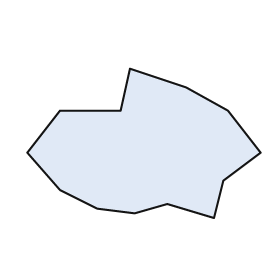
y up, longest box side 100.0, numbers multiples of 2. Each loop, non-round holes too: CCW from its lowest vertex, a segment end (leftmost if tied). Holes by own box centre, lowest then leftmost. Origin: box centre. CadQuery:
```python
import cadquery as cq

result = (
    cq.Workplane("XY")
    .moveTo(30.0, -32.0)
    .lineTo(34.0, -16.0)
    .lineTo(50.0, -4.0)
    .lineTo(36.0, 14.0)
    .lineTo(18.0, 24.0)
    .lineTo(-6.0, 32.0)
    .lineTo(-10.0, 14.0)
    .lineTo(-36.0, 14.0)
    .lineTo(-50.0, -4.0)
    .lineTo(-36.0, -20.0)
    .lineTo(-20.0, -28.0)
    .lineTo(-4.0, -30.0)
    .lineTo(10.0, -26.0)
    .close()
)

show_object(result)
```